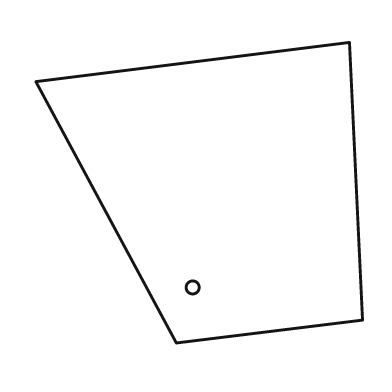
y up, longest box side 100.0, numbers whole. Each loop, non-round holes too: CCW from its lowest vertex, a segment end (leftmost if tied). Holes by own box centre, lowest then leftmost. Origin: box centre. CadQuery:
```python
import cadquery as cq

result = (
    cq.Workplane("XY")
    .moveTo(-7.0, -46.0)
    .lineTo(50.0, -39.0)
    .lineTo(46.0, 46.0)
    .lineTo(-50.0, 34.0)
    .close()
    .moveTo(-2.0, -29.0)
    .circle(2.0)
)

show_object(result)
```